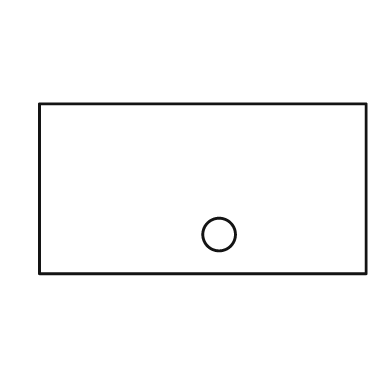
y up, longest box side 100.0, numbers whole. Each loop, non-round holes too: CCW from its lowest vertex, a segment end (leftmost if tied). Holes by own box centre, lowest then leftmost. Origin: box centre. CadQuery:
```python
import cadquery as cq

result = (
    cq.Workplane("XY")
    .moveTo(-50.0, -26.0)
    .lineTo(50.0, -26.0)
    .lineTo(50.0, 26.0)
    .lineTo(-50.0, 26.0)
    .close()
    .moveTo(5.0, -14.0)
    .circle(5.0)
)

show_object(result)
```